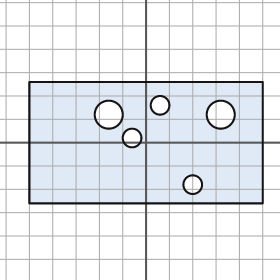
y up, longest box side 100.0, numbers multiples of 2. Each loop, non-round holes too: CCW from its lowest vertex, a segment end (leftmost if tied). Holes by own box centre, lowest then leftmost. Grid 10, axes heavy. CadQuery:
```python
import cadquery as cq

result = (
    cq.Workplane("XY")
    .moveTo(-50.0, -26.0)
    .lineTo(50.0, -26.0)
    .lineTo(50.0, 26.0)
    .lineTo(-50.0, 26.0)
    .close()
    .moveTo(20.0, -18.0)
    .circle(4.0)
    .moveTo(-6.0, 2.0)
    .circle(4.0)
    .moveTo(-16.0, 12.0)
    .circle(6.0)
    .moveTo(32.0, 12.0)
    .circle(6.0)
    .moveTo(6.0, 16.0)
    .circle(4.0)
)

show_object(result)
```